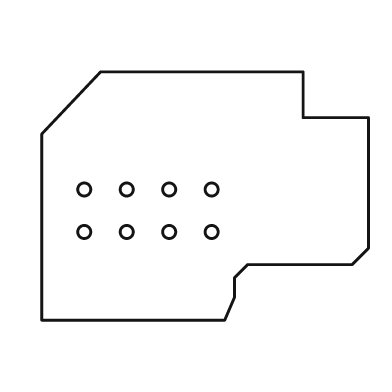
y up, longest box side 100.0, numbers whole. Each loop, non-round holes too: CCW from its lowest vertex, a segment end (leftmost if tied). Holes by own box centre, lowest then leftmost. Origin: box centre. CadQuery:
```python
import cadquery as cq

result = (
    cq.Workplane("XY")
    .moveTo(-50.0, -38.0)
    .lineTo(6.0, -38.0)
    .lineTo(9.0, -31.0)
    .lineTo(9.0, -25.0)
    .lineTo(13.0, -21.0)
    .lineTo(45.0, -21.0)
    .lineTo(50.0, -16.0)
    .lineTo(50.0, 24.0)
    .lineTo(30.0, 24.0)
    .lineTo(30.0, 38.0)
    .lineTo(-32.0, 38.0)
    .lineTo(-50.0, 19.0)
    .close()
    .moveTo(-37.0, -11.0)
    .circle(2.0)
    .moveTo(-24.0, -11.0)
    .circle(2.0)
    .moveTo(-11.0, -11.0)
    .circle(2.0)
    .moveTo(2.0, -11.0)
    .circle(2.0)
    .moveTo(-37.0, 2.0)
    .circle(2.0)
    .moveTo(-24.0, 2.0)
    .circle(2.0)
    .moveTo(-11.0, 2.0)
    .circle(2.0)
    .moveTo(2.0, 2.0)
    .circle(2.0)
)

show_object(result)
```